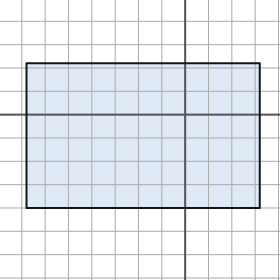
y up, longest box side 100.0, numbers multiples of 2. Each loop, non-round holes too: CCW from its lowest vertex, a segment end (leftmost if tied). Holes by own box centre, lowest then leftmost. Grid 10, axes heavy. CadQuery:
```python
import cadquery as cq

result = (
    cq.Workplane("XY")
    .moveTo(-68.0, -40.0)
    .lineTo(32.0, -40.0)
    .lineTo(32.0, 22.0)
    .lineTo(-68.0, 22.0)
    .close()
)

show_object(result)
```